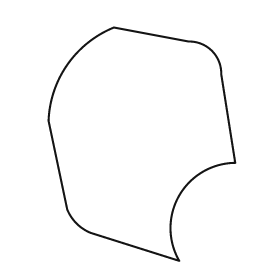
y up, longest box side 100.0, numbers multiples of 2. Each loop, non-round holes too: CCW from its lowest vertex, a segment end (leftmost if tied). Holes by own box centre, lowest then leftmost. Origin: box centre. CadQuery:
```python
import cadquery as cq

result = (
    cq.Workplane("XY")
    .moveTo(16.0, -50.0)
    .threePointArc((16.0, -22.0), (40.0, -8.0))
    .lineTo(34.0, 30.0)
    .threePointArc((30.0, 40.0), (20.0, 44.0))
    .lineTo(-12.0, 50.0)
    .threePointArc((-32.0, 34.0), (-40.0, 10.0))
    .lineTo(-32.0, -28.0)
    .threePointArc((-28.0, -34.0), (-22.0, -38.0))
    .close()
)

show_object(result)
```